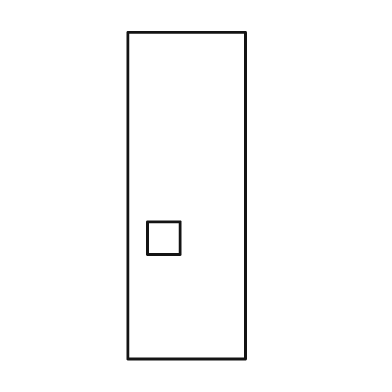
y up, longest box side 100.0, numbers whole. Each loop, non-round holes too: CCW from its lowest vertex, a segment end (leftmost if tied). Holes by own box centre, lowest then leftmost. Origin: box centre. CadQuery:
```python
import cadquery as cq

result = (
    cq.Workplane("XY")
    .moveTo(-18.0, -50.0)
    .lineTo(18.0, -50.0)
    .lineTo(18.0, 50.0)
    .lineTo(-18.0, 50.0)
    .close()
    .moveTo(-12.0, -18.0)
    .lineTo(-2.0, -18.0)
    .lineTo(-2.0, -8.0)
    .lineTo(-12.0, -8.0)
    .close()
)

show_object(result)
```